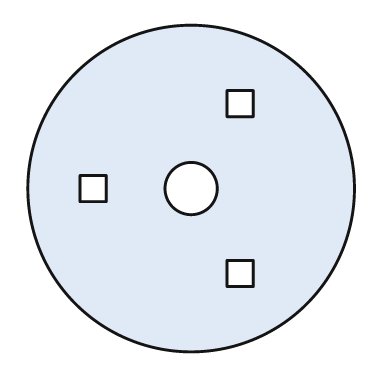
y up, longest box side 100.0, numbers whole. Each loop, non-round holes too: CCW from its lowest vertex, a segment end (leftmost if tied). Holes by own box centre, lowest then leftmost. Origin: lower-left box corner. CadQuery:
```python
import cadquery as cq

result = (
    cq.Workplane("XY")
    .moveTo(50.0, 50.0)
    .circle(50.0)
    .moveTo(61.0, 20.0)
    .lineTo(69.0, 20.0)
    .lineTo(69.0, 28.0)
    .lineTo(61.0, 28.0)
    .close()
    .moveTo(16.0, 46.0)
    .lineTo(24.0, 46.0)
    .lineTo(24.0, 54.0)
    .lineTo(16.0, 54.0)
    .close()
    .moveTo(50.0, 50.0)
    .circle(8.0)
    .moveTo(61.0, 72.0)
    .lineTo(69.0, 72.0)
    .lineTo(69.0, 80.0)
    .lineTo(61.0, 80.0)
    .close()
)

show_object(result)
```